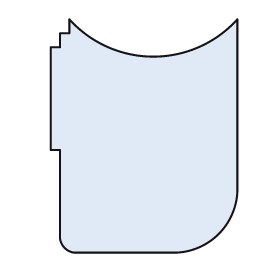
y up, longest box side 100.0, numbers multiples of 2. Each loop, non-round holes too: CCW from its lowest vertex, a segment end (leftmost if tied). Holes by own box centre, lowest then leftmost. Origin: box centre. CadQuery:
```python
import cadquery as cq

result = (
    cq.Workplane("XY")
    .moveTo(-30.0, -50.0)
    .lineTo(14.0, -50.0)
    .threePointArc((32.0, -42.0), (40.0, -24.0))
    .lineTo(40.0, 50.0)
    .threePointArc((4.0, 34.0), (-32.0, 50.0))
    .lineTo(-32.0, 44.0)
    .lineTo(-36.0, 44.0)
    .lineTo(-36.0, 38.0)
    .lineTo(-40.0, 38.0)
    .lineTo(-40.0, -6.0)
    .lineTo(-36.0, -6.0)
    .lineTo(-36.0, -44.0)
    .threePointArc((-34.0, -48.0), (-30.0, -50.0))
    .close()
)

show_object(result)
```